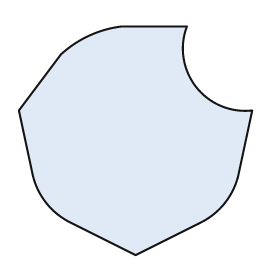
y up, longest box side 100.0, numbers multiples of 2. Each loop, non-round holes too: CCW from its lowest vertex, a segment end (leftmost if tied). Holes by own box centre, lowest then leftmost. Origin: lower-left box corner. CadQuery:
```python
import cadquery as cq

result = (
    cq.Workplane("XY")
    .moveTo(50.0, 0.0)
    .lineTo(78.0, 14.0)
    .threePointArc((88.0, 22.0), (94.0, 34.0))
    .lineTo(100.0, 62.0)
    .threePointArc((76.0, 72.0), (72.0, 98.0))
    .lineTo(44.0, 98.0)
    .threePointArc((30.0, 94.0), (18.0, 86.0))
    .lineTo(0.0, 62.0)
    .lineTo(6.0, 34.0)
    .threePointArc((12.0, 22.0), (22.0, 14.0))
    .close()
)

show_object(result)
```